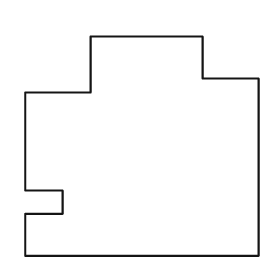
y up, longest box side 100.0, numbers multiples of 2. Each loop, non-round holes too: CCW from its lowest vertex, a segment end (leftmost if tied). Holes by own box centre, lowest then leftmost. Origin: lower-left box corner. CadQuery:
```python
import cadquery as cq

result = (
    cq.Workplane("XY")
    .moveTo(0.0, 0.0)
    .lineTo(100.0, 0.0)
    .lineTo(100.0, 76.0)
    .lineTo(76.0, 76.0)
    .lineTo(76.0, 94.0)
    .lineTo(28.0, 94.0)
    .lineTo(28.0, 70.0)
    .lineTo(0.0, 70.0)
    .lineTo(0.0, 28.0)
    .lineTo(16.0, 28.0)
    .lineTo(16.0, 18.0)
    .lineTo(0.0, 18.0)
    .close()
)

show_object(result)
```